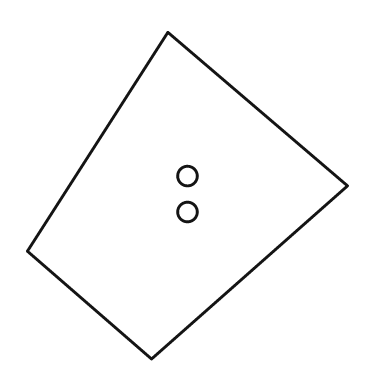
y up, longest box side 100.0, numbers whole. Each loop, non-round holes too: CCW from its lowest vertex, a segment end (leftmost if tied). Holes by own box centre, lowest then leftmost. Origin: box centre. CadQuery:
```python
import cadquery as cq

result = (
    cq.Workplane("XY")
    .moveTo(-11.0, -50.0)
    .lineTo(49.0, 3.0)
    .lineTo(-6.0, 50.0)
    .lineTo(-49.0, -17.0)
    .close()
    .moveTo(0.0, -5.0)
    .circle(3.0)
    .moveTo(0.0, 6.0)
    .circle(3.0)
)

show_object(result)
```